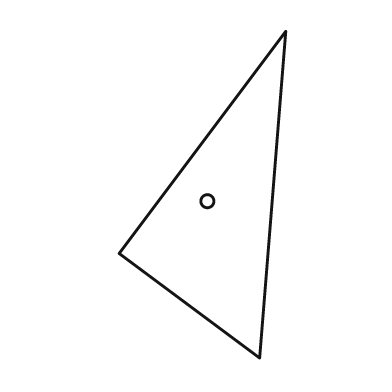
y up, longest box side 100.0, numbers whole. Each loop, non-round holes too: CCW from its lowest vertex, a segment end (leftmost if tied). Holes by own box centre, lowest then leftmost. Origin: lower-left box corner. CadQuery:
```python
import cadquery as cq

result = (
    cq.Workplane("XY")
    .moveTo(43.0, 0.0)
    .lineTo(51.0, 100.0)
    .lineTo(0.0, 32.0)
    .close()
    .moveTo(27.0, 48.0)
    .circle(2.0)
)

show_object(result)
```